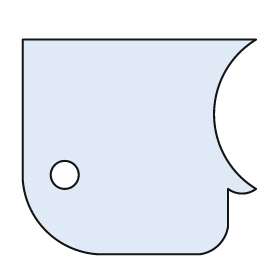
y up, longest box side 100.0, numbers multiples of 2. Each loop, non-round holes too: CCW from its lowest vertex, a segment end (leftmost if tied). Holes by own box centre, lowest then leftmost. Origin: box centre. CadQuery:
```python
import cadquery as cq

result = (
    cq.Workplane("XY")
    .moveTo(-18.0, -46.0)
    .lineTo(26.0, -46.0)
    .threePointArc((34.0, -42.0), (38.0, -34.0))
    .lineTo(38.0, -18.0)
    .threePointArc((44.0, -20.0), (50.0, -18.0))
    .threePointArc((32.0, 14.0), (50.0, 46.0))
    .lineTo(-50.0, 46.0)
    .lineTo(-50.0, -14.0)
    .threePointArc((-40.0, -36.0), (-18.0, -46.0))
    .close()
    .moveTo(-32.0, -12.0)
    .circle(6.0)
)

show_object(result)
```